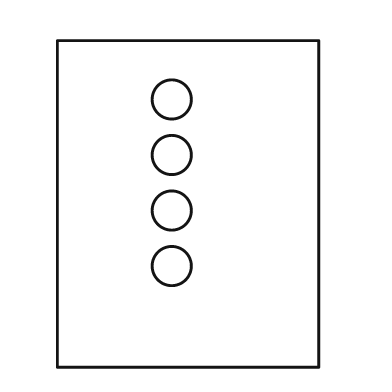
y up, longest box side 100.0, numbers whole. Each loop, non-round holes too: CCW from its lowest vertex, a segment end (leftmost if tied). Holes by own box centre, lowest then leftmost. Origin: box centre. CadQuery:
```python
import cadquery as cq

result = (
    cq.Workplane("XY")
    .moveTo(-40.0, -50.0)
    .lineTo(40.0, -50.0)
    .lineTo(40.0, 50.0)
    .lineTo(-40.0, 50.0)
    .close()
    .moveTo(-5.0, -19.0)
    .circle(6.0)
    .moveTo(-5.0, -2.0)
    .circle(6.0)
    .moveTo(-5.0, 15.0)
    .circle(6.0)
    .moveTo(-5.0, 32.0)
    .circle(6.0)
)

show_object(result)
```